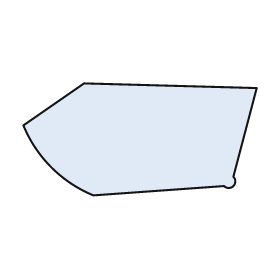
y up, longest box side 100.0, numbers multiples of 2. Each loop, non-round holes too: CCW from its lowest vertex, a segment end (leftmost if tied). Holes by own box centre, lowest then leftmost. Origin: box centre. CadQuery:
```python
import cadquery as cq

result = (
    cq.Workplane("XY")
    .moveTo(-20.0, -24.0)
    .lineTo(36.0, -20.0)
    .threePointArc((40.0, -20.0), (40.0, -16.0))
    .lineTo(50.0, 22.0)
    .lineTo(-24.0, 24.0)
    .lineTo(-50.0, 6.0)
    .threePointArc((-38.0, -12.0), (-20.0, -24.0))
    .close()
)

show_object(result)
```